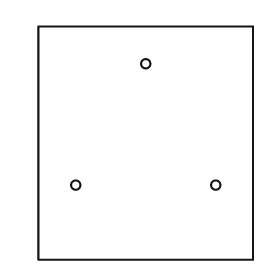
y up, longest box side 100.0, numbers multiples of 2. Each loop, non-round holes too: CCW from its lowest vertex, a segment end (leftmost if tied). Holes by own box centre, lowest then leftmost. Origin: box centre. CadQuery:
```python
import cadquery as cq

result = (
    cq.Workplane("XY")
    .moveTo(-46.0, -50.0)
    .lineTo(46.0, -50.0)
    .lineTo(46.0, 50.0)
    .lineTo(-46.0, 50.0)
    .close()
    .moveTo(-30.0, -18.0)
    .circle(2.0)
    .moveTo(30.0, -18.0)
    .circle(2.0)
    .moveTo(0.0, 34.0)
    .circle(2.0)
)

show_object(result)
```